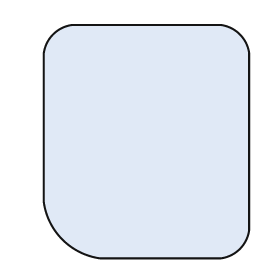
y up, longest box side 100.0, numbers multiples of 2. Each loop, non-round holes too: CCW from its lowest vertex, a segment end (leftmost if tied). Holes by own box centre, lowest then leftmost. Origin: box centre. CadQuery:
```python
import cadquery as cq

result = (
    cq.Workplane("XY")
    .moveTo(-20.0, -50.0)
    .lineTo(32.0, -50.0)
    .threePointArc((40.0, -46.0), (44.0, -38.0))
    .lineTo(44.0, 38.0)
    .threePointArc((40.0, 46.0), (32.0, 50.0))
    .lineTo(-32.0, 50.0)
    .threePointArc((-40.0, 46.0), (-44.0, 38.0))
    .lineTo(-44.0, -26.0)
    .threePointArc((-36.0, -42.0), (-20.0, -50.0))
    .close()
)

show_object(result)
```